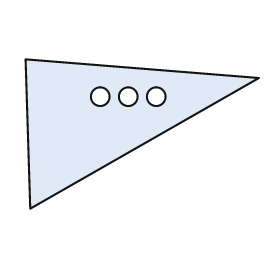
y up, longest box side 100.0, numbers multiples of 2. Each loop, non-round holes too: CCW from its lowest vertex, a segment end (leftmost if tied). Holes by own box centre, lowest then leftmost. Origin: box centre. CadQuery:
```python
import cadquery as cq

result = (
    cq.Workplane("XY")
    .moveTo(-48.0, -32.0)
    .lineTo(50.0, 24.0)
    .lineTo(-50.0, 32.0)
    .close()
    .moveTo(-18.0, 16.0)
    .circle(4.0)
    .moveTo(-6.0, 16.0)
    .circle(4.0)
    .moveTo(6.0, 16.0)
    .circle(4.0)
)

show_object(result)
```